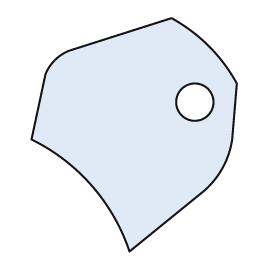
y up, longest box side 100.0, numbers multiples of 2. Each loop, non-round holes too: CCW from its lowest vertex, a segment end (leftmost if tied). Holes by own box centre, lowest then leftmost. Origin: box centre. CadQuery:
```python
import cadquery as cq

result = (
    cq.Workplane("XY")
    .moveTo(-2.0, -50.0)
    .lineTo(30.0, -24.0)
    .threePointArc((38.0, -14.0), (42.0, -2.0))
    .lineTo(44.0, 22.0)
    .threePointArc((32.0, 38.0), (16.0, 50.0))
    .lineTo(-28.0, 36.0)
    .threePointArc((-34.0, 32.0), (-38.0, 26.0))
    .lineTo(-44.0, -2.0)
    .threePointArc((-18.0, -22.0), (-2.0, -50.0))
    .close()
    .moveTo(26.0, 14.0)
    .circle(8.0)
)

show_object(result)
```